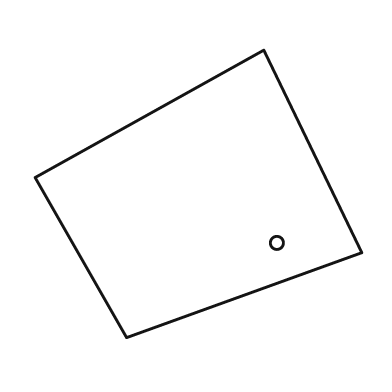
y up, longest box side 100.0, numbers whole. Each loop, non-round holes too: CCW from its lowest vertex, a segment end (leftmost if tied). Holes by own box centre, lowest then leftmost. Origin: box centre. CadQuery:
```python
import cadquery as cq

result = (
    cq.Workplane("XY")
    .moveTo(-22.0, -44.0)
    .lineTo(50.0, -18.0)
    .lineTo(20.0, 44.0)
    .lineTo(-50.0, 5.0)
    .close()
    .moveTo(24.0, -15.0)
    .circle(2.0)
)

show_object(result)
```